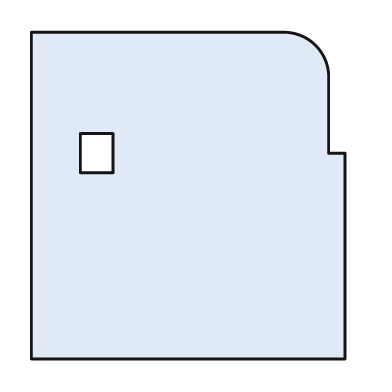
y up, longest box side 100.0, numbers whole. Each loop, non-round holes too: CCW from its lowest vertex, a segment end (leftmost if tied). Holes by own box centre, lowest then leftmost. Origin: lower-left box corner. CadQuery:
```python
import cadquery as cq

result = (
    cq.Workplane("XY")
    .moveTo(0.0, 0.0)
    .lineTo(96.0, 0.0)
    .lineTo(96.0, 63.0)
    .lineTo(91.0, 63.0)
    .lineTo(91.0, 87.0)
    .threePointArc((87.0, 96.0), (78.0, 100.0))
    .lineTo(0.0, 100.0)
    .close()
    .moveTo(15.0, 57.0)
    .lineTo(25.0, 57.0)
    .lineTo(25.0, 69.0)
    .lineTo(15.0, 69.0)
    .close()
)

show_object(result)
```